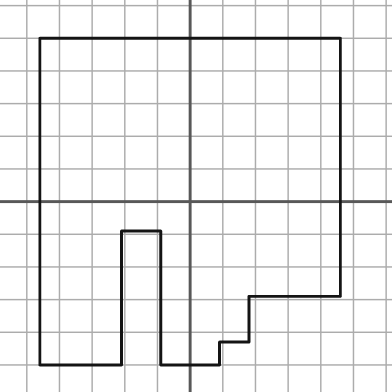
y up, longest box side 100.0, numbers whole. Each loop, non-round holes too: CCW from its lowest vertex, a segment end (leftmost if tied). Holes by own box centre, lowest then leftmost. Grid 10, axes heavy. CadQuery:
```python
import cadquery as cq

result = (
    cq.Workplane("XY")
    .moveTo(-46.0, -50.0)
    .lineTo(-21.0, -50.0)
    .lineTo(-21.0, -9.0)
    .lineTo(-9.0, -9.0)
    .lineTo(-9.0, -50.0)
    .lineTo(9.0, -50.0)
    .lineTo(9.0, -43.0)
    .lineTo(18.0, -43.0)
    .lineTo(18.0, -29.0)
    .lineTo(46.0, -29.0)
    .lineTo(46.0, 50.0)
    .lineTo(-46.0, 50.0)
    .close()
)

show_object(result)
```